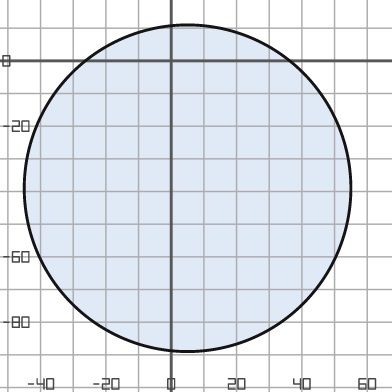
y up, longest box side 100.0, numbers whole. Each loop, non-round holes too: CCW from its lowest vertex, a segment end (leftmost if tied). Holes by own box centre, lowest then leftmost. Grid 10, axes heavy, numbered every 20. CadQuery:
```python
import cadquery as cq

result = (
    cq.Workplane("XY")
    .moveTo(5.0, -39.0)
    .circle(50.0)
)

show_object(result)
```